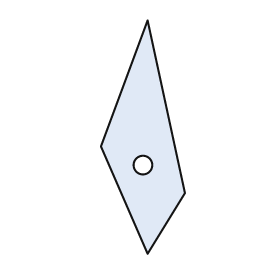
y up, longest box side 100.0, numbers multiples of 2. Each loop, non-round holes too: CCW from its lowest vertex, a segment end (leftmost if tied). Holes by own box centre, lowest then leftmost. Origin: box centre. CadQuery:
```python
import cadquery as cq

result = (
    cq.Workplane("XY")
    .moveTo(2.0, -50.0)
    .lineTo(18.0, -24.0)
    .lineTo(2.0, 50.0)
    .lineTo(-18.0, -4.0)
    .close()
    .moveTo(0.0, -12.0)
    .circle(4.0)
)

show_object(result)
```